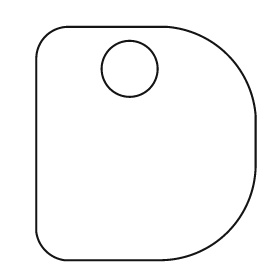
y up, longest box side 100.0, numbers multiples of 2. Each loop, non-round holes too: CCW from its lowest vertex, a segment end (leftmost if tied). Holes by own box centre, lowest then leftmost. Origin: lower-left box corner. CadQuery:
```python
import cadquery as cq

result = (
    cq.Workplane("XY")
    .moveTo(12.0, 0.0)
    .lineTo(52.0, 0.0)
    .threePointArc((82.0, 12.0), (94.0, 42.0))
    .lineTo(94.0, 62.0)
    .threePointArc((82.0, 88.0), (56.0, 100.0))
    .lineTo(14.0, 100.0)
    .threePointArc((4.0, 96.0), (0.0, 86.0))
    .lineTo(0.0, 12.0)
    .threePointArc((4.0, 4.0), (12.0, 0.0))
    .close()
    .moveTo(40.0, 82.0)
    .circle(12.0)
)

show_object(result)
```